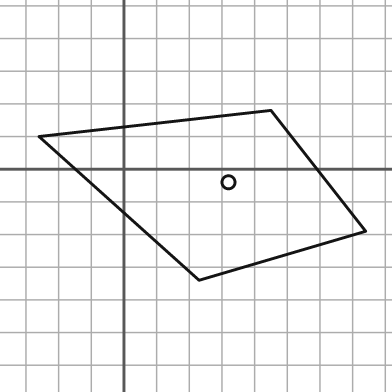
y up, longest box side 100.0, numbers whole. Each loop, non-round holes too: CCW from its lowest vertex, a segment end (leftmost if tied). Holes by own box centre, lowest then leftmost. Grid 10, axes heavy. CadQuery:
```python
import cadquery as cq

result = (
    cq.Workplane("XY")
    .moveTo(23.0, -34.0)
    .lineTo(74.0, -19.0)
    .lineTo(45.0, 18.0)
    .lineTo(-26.0, 10.0)
    .close()
    .moveTo(32.0, -4.0)
    .circle(2.0)
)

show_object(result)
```